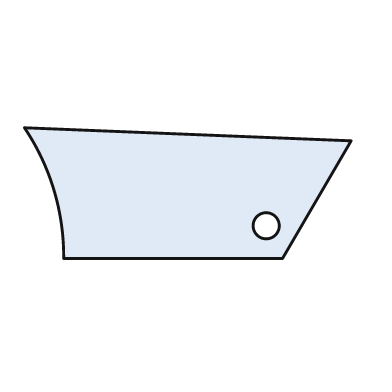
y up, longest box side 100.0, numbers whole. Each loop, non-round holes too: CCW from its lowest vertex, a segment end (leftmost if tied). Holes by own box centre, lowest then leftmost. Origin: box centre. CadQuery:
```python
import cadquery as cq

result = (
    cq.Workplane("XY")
    .moveTo(-38.0, -20.0)
    .lineTo(29.0, -20.0)
    .lineTo(50.0, 16.0)
    .lineTo(-50.0, 20.0)
    .threePointArc((-41.0, 1.0), (-38.0, -20.0))
    .close()
    .moveTo(24.0, -10.0)
    .circle(4.0)
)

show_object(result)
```